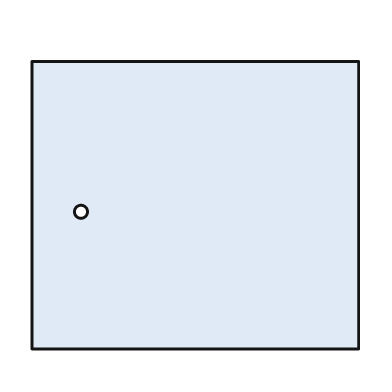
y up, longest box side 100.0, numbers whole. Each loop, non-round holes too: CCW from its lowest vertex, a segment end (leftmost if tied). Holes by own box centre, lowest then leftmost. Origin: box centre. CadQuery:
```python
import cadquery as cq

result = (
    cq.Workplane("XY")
    .moveTo(-50.0, -44.0)
    .lineTo(50.0, -44.0)
    .lineTo(50.0, 44.0)
    .lineTo(-50.0, 44.0)
    .close()
    .moveTo(-35.0, -2.0)
    .circle(2.0)
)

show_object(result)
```